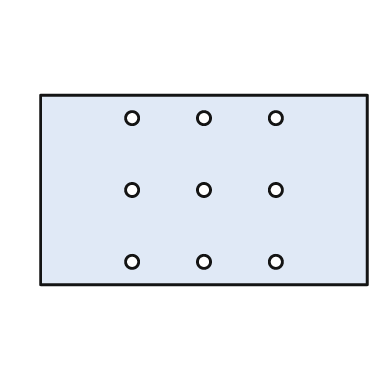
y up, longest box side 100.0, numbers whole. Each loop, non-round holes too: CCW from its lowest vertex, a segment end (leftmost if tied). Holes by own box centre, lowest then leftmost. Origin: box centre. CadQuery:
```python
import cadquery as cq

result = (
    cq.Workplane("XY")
    .moveTo(-50.0, -29.0)
    .lineTo(50.0, -29.0)
    .lineTo(50.0, 29.0)
    .lineTo(-50.0, 29.0)
    .close()
    .moveTo(-22.0, -22.0)
    .circle(2.0)
    .moveTo(0.0, -22.0)
    .circle(2.0)
    .moveTo(22.0, -22.0)
    .circle(2.0)
    .moveTo(-22.0, 0.0)
    .circle(2.0)
    .moveTo(0.0, 0.0)
    .circle(2.0)
    .moveTo(22.0, 0.0)
    .circle(2.0)
    .moveTo(-22.0, 22.0)
    .circle(2.0)
    .moveTo(0.0, 22.0)
    .circle(2.0)
    .moveTo(22.0, 22.0)
    .circle(2.0)
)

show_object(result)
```